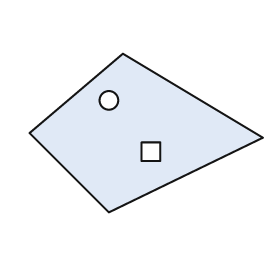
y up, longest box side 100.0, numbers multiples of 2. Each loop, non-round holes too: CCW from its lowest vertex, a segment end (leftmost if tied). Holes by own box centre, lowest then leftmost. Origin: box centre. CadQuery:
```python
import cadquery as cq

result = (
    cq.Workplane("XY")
    .moveTo(-16.0, -34.0)
    .lineTo(50.0, -2.0)
    .lineTo(-10.0, 34.0)
    .lineTo(-50.0, 0.0)
    .close()
    .moveTo(-2.0, -12.0)
    .lineTo(6.0, -12.0)
    .lineTo(6.0, -4.0)
    .lineTo(-2.0, -4.0)
    .close()
    .moveTo(-16.0, 14.0)
    .circle(4.0)
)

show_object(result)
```